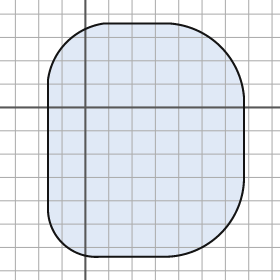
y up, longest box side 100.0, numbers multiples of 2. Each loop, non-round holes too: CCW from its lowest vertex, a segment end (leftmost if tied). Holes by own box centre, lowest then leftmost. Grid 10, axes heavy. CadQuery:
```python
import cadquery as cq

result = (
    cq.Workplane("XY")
    .moveTo(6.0, -64.0)
    .lineTo(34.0, -64.0)
    .threePointArc((58.0, -54.0), (68.0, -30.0))
    .lineTo(68.0, 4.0)
    .threePointArc((58.0, 26.0), (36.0, 36.0))
    .lineTo(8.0, 36.0)
    .threePointArc((-8.0, 28.0), (-16.0, 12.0))
    .lineTo(-16.0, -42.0)
    .threePointArc((-10.0, -58.0), (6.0, -64.0))
    .close()
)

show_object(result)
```